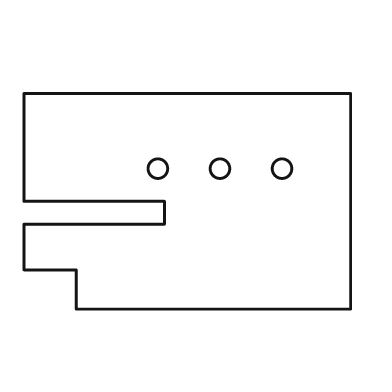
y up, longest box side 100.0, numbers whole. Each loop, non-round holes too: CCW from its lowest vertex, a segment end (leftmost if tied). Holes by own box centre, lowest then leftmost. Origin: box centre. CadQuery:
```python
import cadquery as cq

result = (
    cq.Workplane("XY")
    .moveTo(-34.0, -33.0)
    .lineTo(50.0, -33.0)
    .lineTo(50.0, 33.0)
    .lineTo(-50.0, 33.0)
    .lineTo(-50.0, 0.0)
    .lineTo(-7.0, 0.0)
    .lineTo(-7.0, -7.0)
    .lineTo(-50.0, -7.0)
    .lineTo(-50.0, -21.0)
    .lineTo(-34.0, -21.0)
    .close()
    .moveTo(-9.0, 10.0)
    .circle(3.0)
    .moveTo(10.0, 10.0)
    .circle(3.0)
    .moveTo(29.0, 10.0)
    .circle(3.0)
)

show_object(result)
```